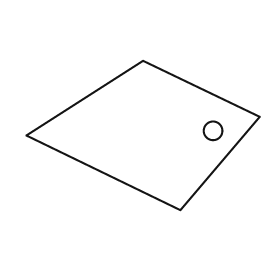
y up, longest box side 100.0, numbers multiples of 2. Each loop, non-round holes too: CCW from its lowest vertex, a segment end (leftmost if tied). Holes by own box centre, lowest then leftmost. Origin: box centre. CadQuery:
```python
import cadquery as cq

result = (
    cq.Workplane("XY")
    .moveTo(16.0, -32.0)
    .lineTo(50.0, 8.0)
    .lineTo(0.0, 32.0)
    .lineTo(-50.0, 0.0)
    .close()
    .moveTo(30.0, 2.0)
    .circle(4.0)
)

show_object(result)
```